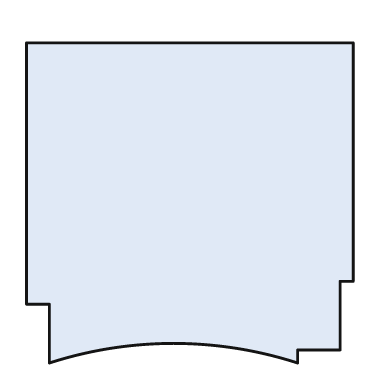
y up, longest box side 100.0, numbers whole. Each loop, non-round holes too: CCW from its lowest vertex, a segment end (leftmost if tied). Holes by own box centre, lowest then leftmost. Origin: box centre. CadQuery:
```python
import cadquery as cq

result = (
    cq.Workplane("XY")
    .moveTo(-43.0, -49.0)
    .threePointArc((-5.0, -43.0), (33.0, -49.0))
    .lineTo(33.0, -45.0)
    .lineTo(46.0, -45.0)
    .lineTo(46.0, -24.0)
    .lineTo(50.0, -24.0)
    .lineTo(50.0, 49.0)
    .lineTo(-50.0, 49.0)
    .lineTo(-50.0, -31.0)
    .lineTo(-43.0, -31.0)
    .close()
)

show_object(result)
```